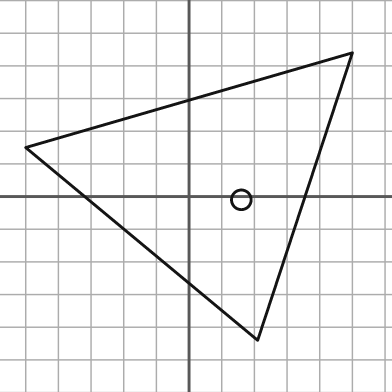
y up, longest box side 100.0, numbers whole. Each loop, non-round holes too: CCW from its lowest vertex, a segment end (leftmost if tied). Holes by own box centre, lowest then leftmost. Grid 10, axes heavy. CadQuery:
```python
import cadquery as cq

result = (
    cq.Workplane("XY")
    .moveTo(21.0, -44.0)
    .lineTo(50.0, 44.0)
    .lineTo(-50.0, 15.0)
    .close()
    .moveTo(16.0, -1.0)
    .circle(3.0)
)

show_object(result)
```